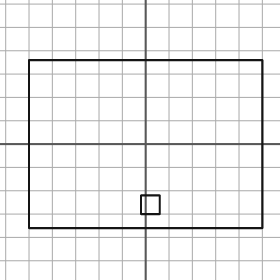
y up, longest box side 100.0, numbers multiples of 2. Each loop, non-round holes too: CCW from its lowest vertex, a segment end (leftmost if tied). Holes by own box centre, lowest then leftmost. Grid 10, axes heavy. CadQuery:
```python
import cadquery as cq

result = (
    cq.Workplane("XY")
    .moveTo(-50.0, -36.0)
    .lineTo(50.0, -36.0)
    .lineTo(50.0, 36.0)
    .lineTo(-50.0, 36.0)
    .close()
    .moveTo(-2.0, -30.0)
    .lineTo(6.0, -30.0)
    .lineTo(6.0, -22.0)
    .lineTo(-2.0, -22.0)
    .close()
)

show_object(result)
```